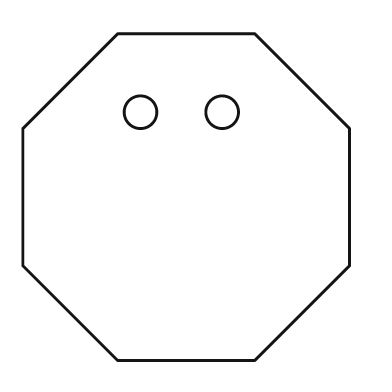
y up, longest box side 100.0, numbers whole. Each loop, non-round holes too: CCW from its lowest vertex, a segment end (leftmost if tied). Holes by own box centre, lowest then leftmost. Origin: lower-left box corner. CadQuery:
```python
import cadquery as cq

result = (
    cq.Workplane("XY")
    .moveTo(29.0, 0.0)
    .lineTo(71.0, 0.0)
    .lineTo(100.0, 29.0)
    .lineTo(100.0, 71.0)
    .lineTo(71.0, 100.0)
    .lineTo(29.0, 100.0)
    .lineTo(0.0, 71.0)
    .lineTo(0.0, 29.0)
    .close()
    .moveTo(36.0, 76.0)
    .circle(5.0)
    .moveTo(61.0, 76.0)
    .circle(5.0)
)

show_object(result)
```